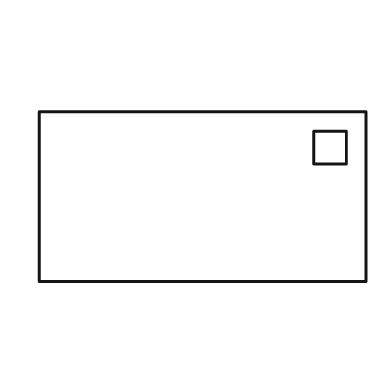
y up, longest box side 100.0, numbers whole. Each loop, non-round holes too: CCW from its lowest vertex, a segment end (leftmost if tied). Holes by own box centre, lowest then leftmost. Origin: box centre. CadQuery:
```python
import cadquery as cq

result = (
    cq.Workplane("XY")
    .moveTo(-50.0, -26.0)
    .lineTo(50.0, -26.0)
    .lineTo(50.0, 26.0)
    .lineTo(-50.0, 26.0)
    .close()
    .moveTo(34.0, 10.0)
    .lineTo(44.0, 10.0)
    .lineTo(44.0, 20.0)
    .lineTo(34.0, 20.0)
    .close()
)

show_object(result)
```